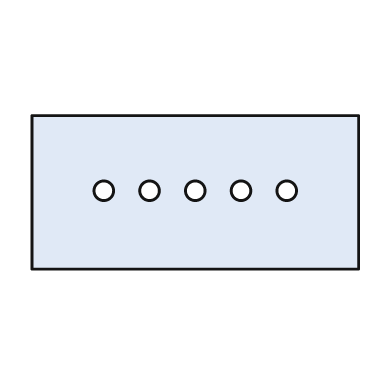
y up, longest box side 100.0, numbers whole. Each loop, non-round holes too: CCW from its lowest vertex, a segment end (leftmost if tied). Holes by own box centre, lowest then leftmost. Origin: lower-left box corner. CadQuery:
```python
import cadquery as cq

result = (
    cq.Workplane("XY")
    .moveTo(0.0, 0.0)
    .lineTo(100.0, 0.0)
    .lineTo(100.0, 47.0)
    .lineTo(0.0, 47.0)
    .close()
    .moveTo(22.0, 24.0)
    .circle(3.0)
    .moveTo(36.0, 24.0)
    .circle(3.0)
    .moveTo(50.0, 24.0)
    .circle(3.0)
    .moveTo(64.0, 24.0)
    .circle(3.0)
    .moveTo(78.0, 24.0)
    .circle(3.0)
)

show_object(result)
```